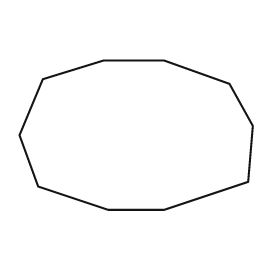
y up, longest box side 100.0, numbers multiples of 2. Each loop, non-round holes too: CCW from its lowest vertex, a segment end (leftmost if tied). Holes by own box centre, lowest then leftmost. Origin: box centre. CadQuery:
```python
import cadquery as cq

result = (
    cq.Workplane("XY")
    .moveTo(-12.0, -32.0)
    .lineTo(12.0, -32.0)
    .lineTo(48.0, -20.0)
    .lineTo(50.0, 4.0)
    .lineTo(40.0, 22.0)
    .lineTo(12.0, 32.0)
    .lineTo(-14.0, 32.0)
    .lineTo(-40.0, 24.0)
    .lineTo(-50.0, 0.0)
    .lineTo(-42.0, -22.0)
    .close()
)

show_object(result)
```